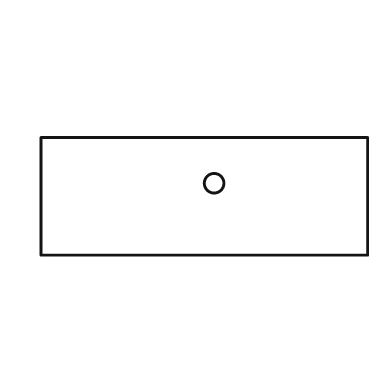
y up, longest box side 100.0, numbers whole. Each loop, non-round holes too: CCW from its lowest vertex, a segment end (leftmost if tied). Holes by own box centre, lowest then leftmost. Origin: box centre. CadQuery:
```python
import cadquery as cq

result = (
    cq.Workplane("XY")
    .moveTo(-50.0, -18.0)
    .lineTo(50.0, -18.0)
    .lineTo(50.0, 18.0)
    .lineTo(-50.0, 18.0)
    .close()
    .moveTo(3.0, 4.0)
    .circle(3.0)
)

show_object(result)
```